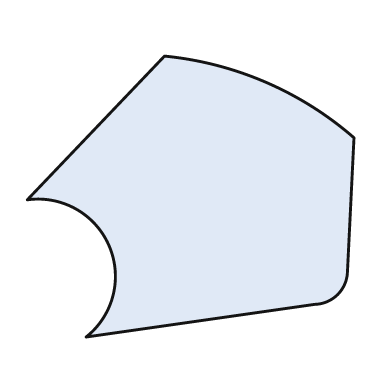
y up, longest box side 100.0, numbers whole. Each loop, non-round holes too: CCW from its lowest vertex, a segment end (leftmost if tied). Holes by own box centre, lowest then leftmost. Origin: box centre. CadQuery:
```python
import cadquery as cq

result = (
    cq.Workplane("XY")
    .moveTo(-32.0, -43.0)
    .lineTo(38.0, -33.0)
    .threePointArc((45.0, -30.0), (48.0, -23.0))
    .lineTo(50.0, 18.0)
    .threePointArc((23.0, 35.0), (-8.0, 43.0))
    .lineTo(-50.0, -1.0)
    .threePointArc((-25.0, -15.0), (-32.0, -43.0))
    .close()
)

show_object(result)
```